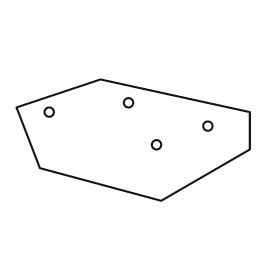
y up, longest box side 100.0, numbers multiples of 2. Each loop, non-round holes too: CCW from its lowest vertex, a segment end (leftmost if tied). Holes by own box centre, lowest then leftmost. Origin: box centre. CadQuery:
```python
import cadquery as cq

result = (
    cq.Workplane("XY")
    .moveTo(12.0, -26.0)
    .lineTo(50.0, -4.0)
    .lineTo(50.0, 12.0)
    .lineTo(-14.0, 26.0)
    .lineTo(-50.0, 14.0)
    .lineTo(-40.0, -12.0)
    .close()
    .moveTo(10.0, -2.0)
    .circle(2.0)
    .moveTo(32.0, 6.0)
    .circle(2.0)
    .moveTo(-36.0, 12.0)
    .circle(2.0)
    .moveTo(-2.0, 16.0)
    .circle(2.0)
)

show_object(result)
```